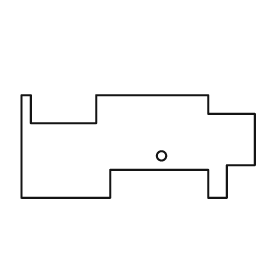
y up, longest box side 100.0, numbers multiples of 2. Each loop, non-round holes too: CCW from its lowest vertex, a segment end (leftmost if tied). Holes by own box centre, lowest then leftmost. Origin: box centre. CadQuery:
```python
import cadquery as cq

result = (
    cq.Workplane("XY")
    .moveTo(-50.0, -22.0)
    .lineTo(-12.0, -22.0)
    .lineTo(-12.0, -10.0)
    .lineTo(30.0, -10.0)
    .lineTo(30.0, -22.0)
    .lineTo(38.0, -22.0)
    .lineTo(38.0, -8.0)
    .lineTo(50.0, -8.0)
    .lineTo(50.0, 14.0)
    .lineTo(30.0, 14.0)
    .lineTo(30.0, 22.0)
    .lineTo(-18.0, 22.0)
    .lineTo(-18.0, 10.0)
    .lineTo(-46.0, 10.0)
    .lineTo(-46.0, 22.0)
    .lineTo(-50.0, 22.0)
    .close()
    .moveTo(10.0, -4.0)
    .circle(2.0)
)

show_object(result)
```